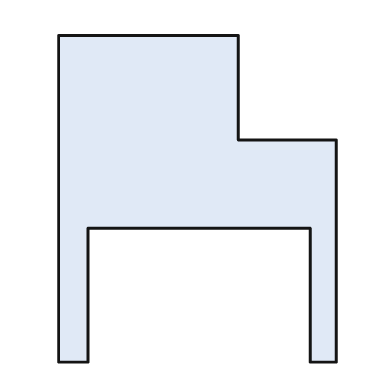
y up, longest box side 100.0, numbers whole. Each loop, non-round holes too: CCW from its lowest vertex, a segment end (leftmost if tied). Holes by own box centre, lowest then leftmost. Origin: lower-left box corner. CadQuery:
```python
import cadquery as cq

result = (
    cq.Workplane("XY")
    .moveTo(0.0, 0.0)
    .lineTo(9.0, 0.0)
    .lineTo(9.0, 41.0)
    .lineTo(77.0, 41.0)
    .lineTo(77.0, 0.0)
    .lineTo(85.0, 0.0)
    .lineTo(85.0, 68.0)
    .lineTo(55.0, 68.0)
    .lineTo(55.0, 100.0)
    .lineTo(0.0, 100.0)
    .close()
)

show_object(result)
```